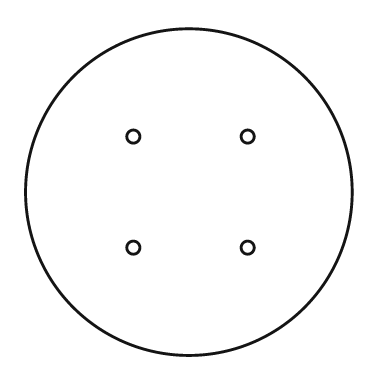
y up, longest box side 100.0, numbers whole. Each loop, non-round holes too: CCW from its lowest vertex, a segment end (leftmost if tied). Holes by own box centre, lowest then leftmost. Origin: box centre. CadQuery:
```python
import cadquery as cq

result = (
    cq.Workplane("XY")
    .moveTo(0.0, 0.0)
    .circle(50.0)
    .moveTo(-17.0, -17.0)
    .circle(2.0)
    .moveTo(18.0, -17.0)
    .circle(2.0)
    .moveTo(-17.0, 17.0)
    .circle(2.0)
    .moveTo(18.0, 17.0)
    .circle(2.0)
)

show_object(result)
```